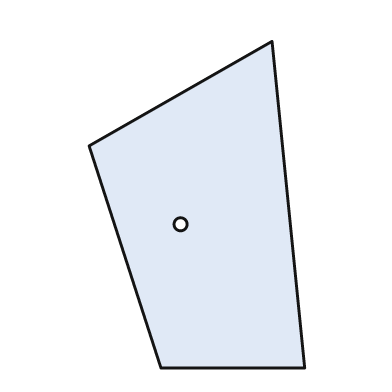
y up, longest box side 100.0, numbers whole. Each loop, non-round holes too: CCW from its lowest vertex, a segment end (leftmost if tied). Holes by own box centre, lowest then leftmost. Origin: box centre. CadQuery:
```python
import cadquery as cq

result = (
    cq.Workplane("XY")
    .moveTo(-11.0, -50.0)
    .lineTo(33.0, -50.0)
    .lineTo(23.0, 50.0)
    .lineTo(-33.0, 18.0)
    .close()
    .moveTo(-5.0, -6.0)
    .circle(2.0)
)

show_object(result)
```